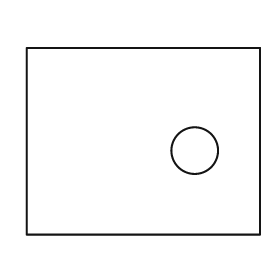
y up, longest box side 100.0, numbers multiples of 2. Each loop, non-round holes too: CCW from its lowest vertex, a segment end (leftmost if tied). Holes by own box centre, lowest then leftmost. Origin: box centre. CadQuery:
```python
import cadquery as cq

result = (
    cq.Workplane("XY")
    .moveTo(-50.0, -40.0)
    .lineTo(50.0, -40.0)
    .lineTo(50.0, 40.0)
    .lineTo(-50.0, 40.0)
    .close()
    .moveTo(22.0, -4.0)
    .circle(10.0)
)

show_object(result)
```